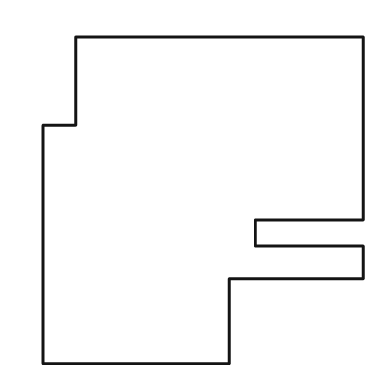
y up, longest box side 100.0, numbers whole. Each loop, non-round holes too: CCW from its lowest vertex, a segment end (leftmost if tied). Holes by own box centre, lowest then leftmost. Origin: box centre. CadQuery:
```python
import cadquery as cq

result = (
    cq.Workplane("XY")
    .moveTo(-49.0, -50.0)
    .lineTo(8.0, -50.0)
    .lineTo(8.0, -24.0)
    .lineTo(49.0, -24.0)
    .lineTo(49.0, -14.0)
    .lineTo(16.0, -14.0)
    .lineTo(16.0, -6.0)
    .lineTo(49.0, -6.0)
    .lineTo(49.0, 50.0)
    .lineTo(-39.0, 50.0)
    .lineTo(-39.0, 23.0)
    .lineTo(-49.0, 23.0)
    .close()
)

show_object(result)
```